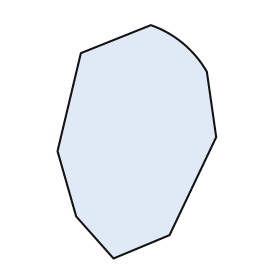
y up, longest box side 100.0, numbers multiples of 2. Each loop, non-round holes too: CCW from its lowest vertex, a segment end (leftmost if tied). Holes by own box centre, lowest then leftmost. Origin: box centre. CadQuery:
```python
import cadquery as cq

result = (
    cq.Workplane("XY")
    .moveTo(-10.0, -50.0)
    .lineTo(14.0, -40.0)
    .lineTo(34.0, 2.0)
    .lineTo(30.0, 30.0)
    .threePointArc((20.0, 42.0), (6.0, 50.0))
    .lineTo(-24.0, 38.0)
    .lineTo(-34.0, -4.0)
    .lineTo(-26.0, -32.0)
    .close()
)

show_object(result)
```